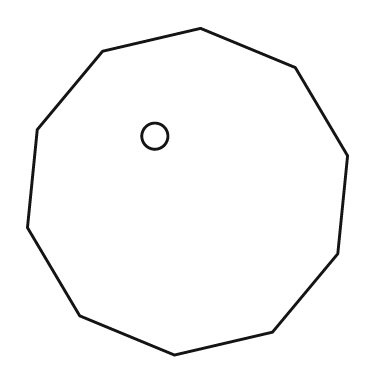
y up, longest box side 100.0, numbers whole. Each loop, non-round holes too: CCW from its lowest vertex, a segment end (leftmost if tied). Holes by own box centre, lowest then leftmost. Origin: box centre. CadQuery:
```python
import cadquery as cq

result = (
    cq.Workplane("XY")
    .moveTo(-4.0, -50.0)
    .lineTo(26.0, -43.0)
    .lineTo(46.0, -19.0)
    .lineTo(49.0, 11.0)
    .lineTo(33.0, 38.0)
    .lineTo(4.0, 50.0)
    .lineTo(-26.0, 43.0)
    .lineTo(-46.0, 19.0)
    .lineTo(-49.0, -11.0)
    .lineTo(-33.0, -38.0)
    .close()
    .moveTo(-10.0, 17.0)
    .circle(4.0)
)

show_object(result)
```